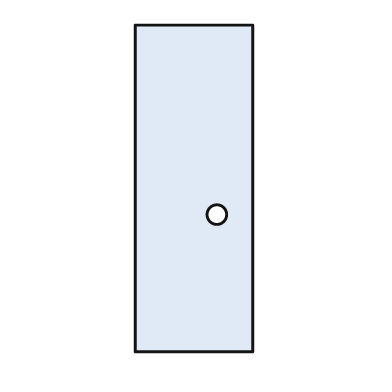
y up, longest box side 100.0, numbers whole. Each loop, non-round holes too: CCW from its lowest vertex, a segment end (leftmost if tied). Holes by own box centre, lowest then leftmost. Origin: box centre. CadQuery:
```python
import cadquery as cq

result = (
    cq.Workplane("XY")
    .moveTo(-18.0, -50.0)
    .lineTo(18.0, -50.0)
    .lineTo(18.0, 50.0)
    .lineTo(-18.0, 50.0)
    .close()
    .moveTo(7.0, -8.0)
    .circle(3.0)
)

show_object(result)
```